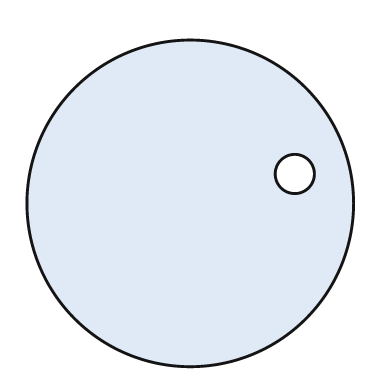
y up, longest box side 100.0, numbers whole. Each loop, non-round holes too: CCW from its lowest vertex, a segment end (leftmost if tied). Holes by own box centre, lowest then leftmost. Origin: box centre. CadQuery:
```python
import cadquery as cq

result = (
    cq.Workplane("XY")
    .moveTo(0.0, 0.0)
    .circle(50.0)
    .moveTo(32.0, 9.0)
    .circle(6.0)
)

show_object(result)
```